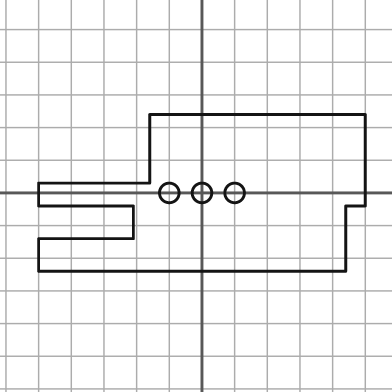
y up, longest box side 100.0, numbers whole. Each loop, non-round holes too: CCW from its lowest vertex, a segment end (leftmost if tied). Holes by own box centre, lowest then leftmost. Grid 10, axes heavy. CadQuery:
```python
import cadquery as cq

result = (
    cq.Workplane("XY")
    .moveTo(-50.0, -24.0)
    .lineTo(44.0, -24.0)
    .lineTo(44.0, -4.0)
    .lineTo(50.0, -4.0)
    .lineTo(50.0, 24.0)
    .lineTo(-16.0, 24.0)
    .lineTo(-16.0, 3.0)
    .lineTo(-50.0, 3.0)
    .lineTo(-50.0, -4.0)
    .lineTo(-21.0, -4.0)
    .lineTo(-21.0, -14.0)
    .lineTo(-50.0, -14.0)
    .close()
    .moveTo(-10.0, 0.0)
    .circle(3.0)
    .moveTo(0.0, 0.0)
    .circle(3.0)
    .moveTo(10.0, 0.0)
    .circle(3.0)
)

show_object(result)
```